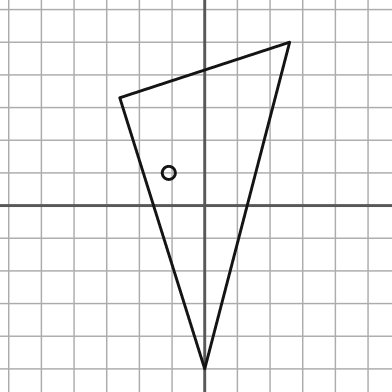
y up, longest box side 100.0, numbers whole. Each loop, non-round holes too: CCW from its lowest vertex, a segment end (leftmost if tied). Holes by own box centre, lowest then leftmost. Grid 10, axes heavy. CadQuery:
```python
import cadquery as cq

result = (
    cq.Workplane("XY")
    .moveTo(0.0, -50.0)
    .lineTo(26.0, 50.0)
    .lineTo(-26.0, 33.0)
    .close()
    .moveTo(-11.0, 10.0)
    .circle(2.0)
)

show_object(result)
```